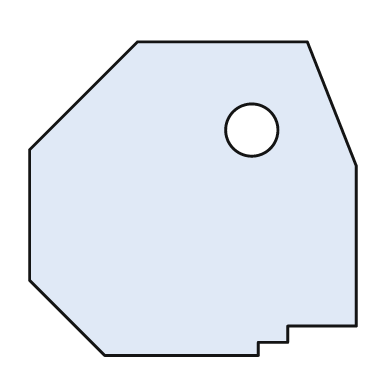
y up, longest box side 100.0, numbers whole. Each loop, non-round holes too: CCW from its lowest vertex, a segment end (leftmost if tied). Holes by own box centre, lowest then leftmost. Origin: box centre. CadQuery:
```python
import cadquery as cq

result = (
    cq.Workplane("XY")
    .moveTo(-27.0, -48.0)
    .lineTo(20.0, -48.0)
    .lineTo(20.0, -44.0)
    .lineTo(29.0, -44.0)
    .lineTo(29.0, -39.0)
    .lineTo(50.0, -39.0)
    .lineTo(50.0, 10.0)
    .lineTo(35.0, 48.0)
    .lineTo(-17.0, 48.0)
    .lineTo(-50.0, 15.0)
    .lineTo(-50.0, -25.0)
    .close()
    .moveTo(18.0, 21.0)
    .circle(8.0)
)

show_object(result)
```